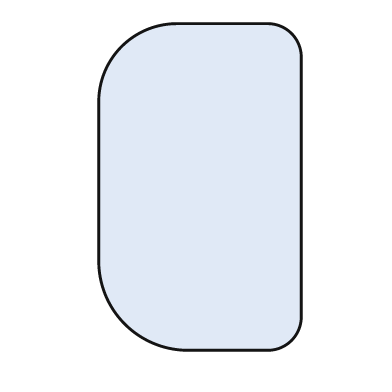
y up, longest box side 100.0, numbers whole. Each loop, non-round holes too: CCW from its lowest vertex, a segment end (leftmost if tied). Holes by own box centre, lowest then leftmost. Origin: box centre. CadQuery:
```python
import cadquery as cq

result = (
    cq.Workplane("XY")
    .moveTo(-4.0, -50.0)
    .lineTo(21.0, -50.0)
    .threePointArc((28.0, -47.0), (31.0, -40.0))
    .lineTo(31.0, 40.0)
    .threePointArc((28.0, 47.0), (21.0, 50.0))
    .lineTo(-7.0, 50.0)
    .threePointArc((-24.0, 43.0), (-31.0, 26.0))
    .lineTo(-31.0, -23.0)
    .threePointArc((-23.0, -42.0), (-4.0, -50.0))
    .close()
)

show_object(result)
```